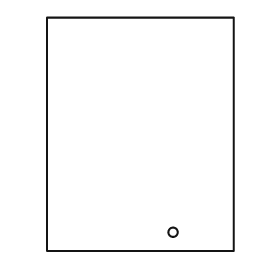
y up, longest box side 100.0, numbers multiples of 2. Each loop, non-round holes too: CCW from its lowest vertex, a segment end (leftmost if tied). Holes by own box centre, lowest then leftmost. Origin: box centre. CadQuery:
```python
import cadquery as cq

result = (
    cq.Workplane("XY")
    .moveTo(-40.0, -50.0)
    .lineTo(40.0, -50.0)
    .lineTo(40.0, 50.0)
    .lineTo(-40.0, 50.0)
    .close()
    .moveTo(14.0, -42.0)
    .circle(2.0)
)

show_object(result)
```